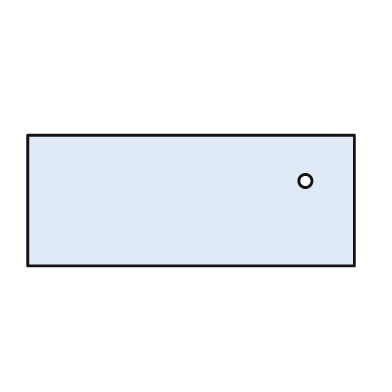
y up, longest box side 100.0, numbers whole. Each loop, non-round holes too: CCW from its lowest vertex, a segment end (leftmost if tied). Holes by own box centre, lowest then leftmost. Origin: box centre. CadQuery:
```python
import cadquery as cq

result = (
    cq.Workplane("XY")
    .moveTo(-50.0, -20.0)
    .lineTo(50.0, -20.0)
    .lineTo(50.0, 20.0)
    .lineTo(-50.0, 20.0)
    .close()
    .moveTo(35.0, 6.0)
    .circle(2.0)
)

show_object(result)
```